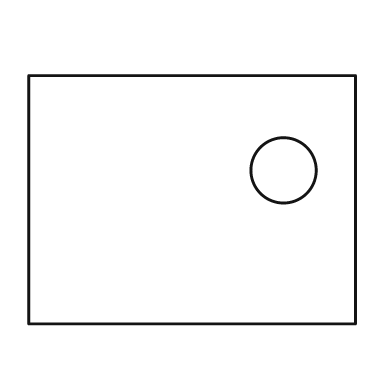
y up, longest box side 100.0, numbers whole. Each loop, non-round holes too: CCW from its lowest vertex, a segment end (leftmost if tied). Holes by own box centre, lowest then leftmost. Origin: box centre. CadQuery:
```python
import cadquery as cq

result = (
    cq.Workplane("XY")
    .moveTo(-50.0, -38.0)
    .lineTo(50.0, -38.0)
    .lineTo(50.0, 38.0)
    .lineTo(-50.0, 38.0)
    .close()
    .moveTo(28.0, 9.0)
    .circle(10.0)
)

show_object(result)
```